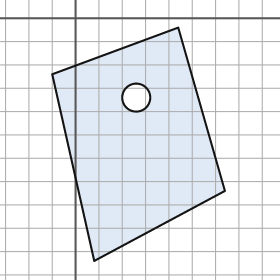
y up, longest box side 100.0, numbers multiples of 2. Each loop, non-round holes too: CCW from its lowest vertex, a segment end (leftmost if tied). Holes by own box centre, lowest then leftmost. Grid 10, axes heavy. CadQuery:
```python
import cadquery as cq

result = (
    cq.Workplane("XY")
    .moveTo(8.0, -104.0)
    .lineTo(64.0, -74.0)
    .lineTo(44.0, -4.0)
    .lineTo(-10.0, -24.0)
    .close()
    .moveTo(26.0, -34.0)
    .circle(6.0)
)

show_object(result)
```